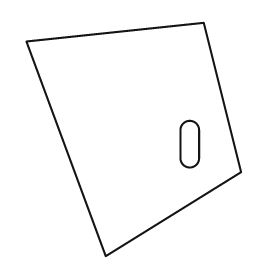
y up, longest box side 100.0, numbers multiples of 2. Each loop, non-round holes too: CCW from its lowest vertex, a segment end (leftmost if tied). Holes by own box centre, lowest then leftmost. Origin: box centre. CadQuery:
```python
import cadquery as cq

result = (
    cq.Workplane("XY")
    .moveTo(-12.0, -50.0)
    .lineTo(46.0, -14.0)
    .lineTo(30.0, 50.0)
    .lineTo(-46.0, 42.0)
    .close()
    .moveTo(20.0, -8.0)
    .threePointArc((24.0, -12.0), (28.0, -8.0))
    .lineTo(28.0, 4.0)
    .threePointArc((24.0, 8.0), (20.0, 4.0))
    .close()
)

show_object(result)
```